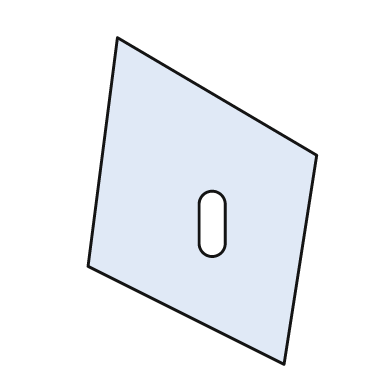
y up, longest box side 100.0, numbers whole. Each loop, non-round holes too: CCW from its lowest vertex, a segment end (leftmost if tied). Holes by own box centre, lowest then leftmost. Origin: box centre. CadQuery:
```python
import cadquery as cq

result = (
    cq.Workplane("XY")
    .moveTo(25.0, -50.0)
    .lineTo(35.0, 14.0)
    .lineTo(-26.0, 50.0)
    .lineTo(-35.0, -20.0)
    .close()
    .moveTo(-1.0, -13.0)
    .threePointArc((3.0, -17.0), (7.0, -13.0))
    .lineTo(7.0, -1.0)
    .threePointArc((3.0, 3.0), (-1.0, -1.0))
    .close()
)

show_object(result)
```